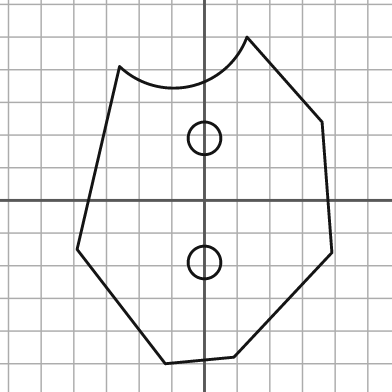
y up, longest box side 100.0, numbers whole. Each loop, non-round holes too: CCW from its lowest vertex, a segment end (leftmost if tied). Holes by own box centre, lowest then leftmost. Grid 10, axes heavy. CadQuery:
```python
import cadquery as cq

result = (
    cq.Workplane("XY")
    .moveTo(-12.0, -50.0)
    .lineTo(9.0, -48.0)
    .lineTo(39.0, -16.0)
    .lineTo(36.0, 24.0)
    .lineTo(13.0, 50.0)
    .threePointArc((-4.0, 35.0), (-26.0, 41.0))
    .lineTo(-39.0, -15.0)
    .close()
    .moveTo(0.0, -19.0)
    .circle(5.0)
    .moveTo(0.0, 19.0)
    .circle(5.0)
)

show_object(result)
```